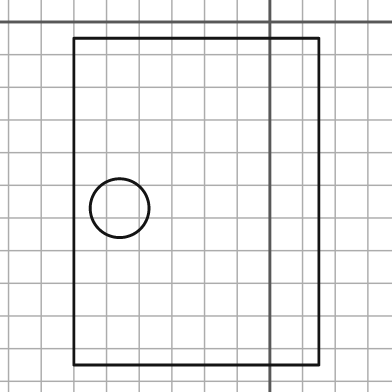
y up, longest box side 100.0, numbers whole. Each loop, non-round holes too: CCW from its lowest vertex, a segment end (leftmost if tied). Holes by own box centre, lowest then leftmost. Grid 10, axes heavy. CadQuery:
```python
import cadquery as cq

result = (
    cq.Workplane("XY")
    .moveTo(-60.0, -105.0)
    .lineTo(15.0, -105.0)
    .lineTo(15.0, -5.0)
    .lineTo(-60.0, -5.0)
    .close()
    .moveTo(-46.0, -57.0)
    .circle(9.0)
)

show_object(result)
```